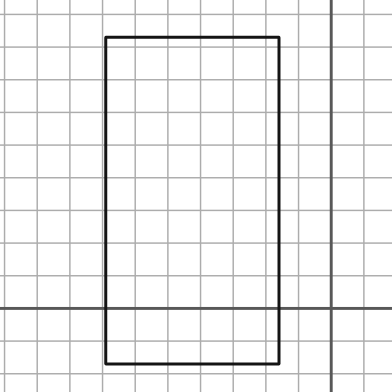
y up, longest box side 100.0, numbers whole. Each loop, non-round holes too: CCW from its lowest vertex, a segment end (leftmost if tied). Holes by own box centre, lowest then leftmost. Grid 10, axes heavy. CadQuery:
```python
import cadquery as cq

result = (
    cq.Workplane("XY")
    .moveTo(-69.0, -17.0)
    .lineTo(-16.0, -17.0)
    .lineTo(-16.0, 83.0)
    .lineTo(-69.0, 83.0)
    .close()
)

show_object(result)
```